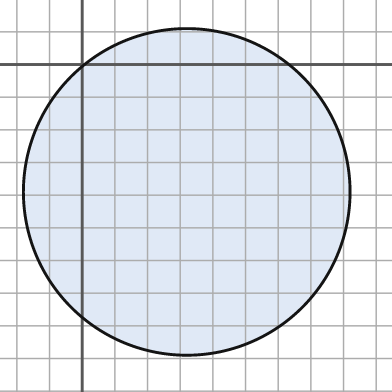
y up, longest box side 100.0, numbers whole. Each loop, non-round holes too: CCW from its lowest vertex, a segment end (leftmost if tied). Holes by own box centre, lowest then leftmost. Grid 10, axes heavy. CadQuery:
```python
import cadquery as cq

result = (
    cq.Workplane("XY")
    .moveTo(32.0, -39.0)
    .circle(50.0)
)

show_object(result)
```